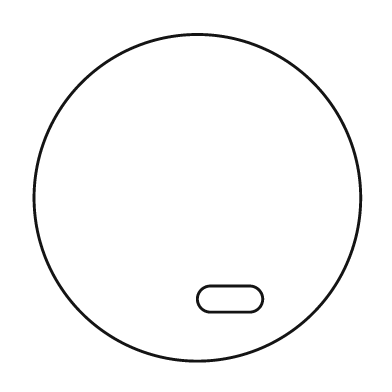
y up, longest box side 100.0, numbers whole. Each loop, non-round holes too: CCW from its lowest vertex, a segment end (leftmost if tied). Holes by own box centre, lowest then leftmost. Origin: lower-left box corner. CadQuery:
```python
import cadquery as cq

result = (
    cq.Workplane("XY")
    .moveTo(50.0, 50.0)
    .circle(50.0)
    .moveTo(54.0, 15.0)
    .lineTo(66.0, 15.0)
    .threePointArc((70.0, 19.0), (66.0, 23.0))
    .lineTo(54.0, 23.0)
    .threePointArc((50.0, 19.0), (54.0, 15.0))
    .close()
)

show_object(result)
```